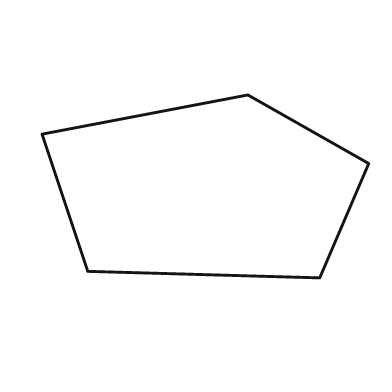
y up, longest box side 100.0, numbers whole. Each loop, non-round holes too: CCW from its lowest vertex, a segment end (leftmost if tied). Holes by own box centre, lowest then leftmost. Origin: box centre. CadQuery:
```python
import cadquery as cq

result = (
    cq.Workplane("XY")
    .moveTo(35.0, -28.0)
    .lineTo(50.0, 7.0)
    .lineTo(13.0, 28.0)
    .lineTo(-50.0, 16.0)
    .lineTo(-36.0, -26.0)
    .close()
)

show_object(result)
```